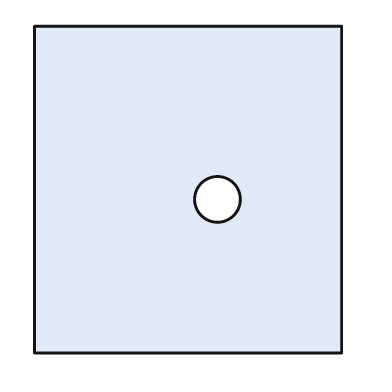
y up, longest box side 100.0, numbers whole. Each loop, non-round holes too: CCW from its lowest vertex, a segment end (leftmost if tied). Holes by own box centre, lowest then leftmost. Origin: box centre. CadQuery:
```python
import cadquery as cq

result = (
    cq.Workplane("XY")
    .moveTo(-47.0, -50.0)
    .lineTo(47.0, -50.0)
    .lineTo(47.0, 50.0)
    .lineTo(-47.0, 50.0)
    .close()
    .moveTo(9.0, -3.0)
    .circle(7.0)
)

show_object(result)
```